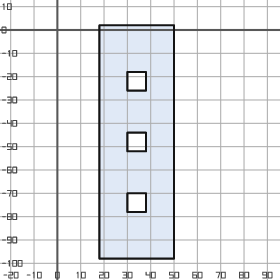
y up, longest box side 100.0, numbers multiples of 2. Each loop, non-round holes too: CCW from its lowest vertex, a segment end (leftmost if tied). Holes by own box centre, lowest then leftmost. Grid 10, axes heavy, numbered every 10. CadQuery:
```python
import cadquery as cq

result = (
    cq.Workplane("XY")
    .moveTo(18.0, -98.0)
    .lineTo(50.0, -98.0)
    .lineTo(50.0, 2.0)
    .lineTo(18.0, 2.0)
    .close()
    .moveTo(30.0, -78.0)
    .lineTo(38.0, -78.0)
    .lineTo(38.0, -70.0)
    .lineTo(30.0, -70.0)
    .close()
    .moveTo(30.0, -52.0)
    .lineTo(38.0, -52.0)
    .lineTo(38.0, -44.0)
    .lineTo(30.0, -44.0)
    .close()
    .moveTo(30.0, -26.0)
    .lineTo(38.0, -26.0)
    .lineTo(38.0, -18.0)
    .lineTo(30.0, -18.0)
    .close()
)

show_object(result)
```